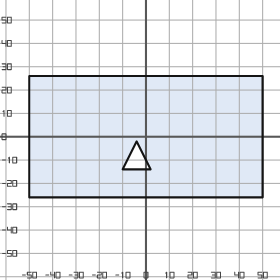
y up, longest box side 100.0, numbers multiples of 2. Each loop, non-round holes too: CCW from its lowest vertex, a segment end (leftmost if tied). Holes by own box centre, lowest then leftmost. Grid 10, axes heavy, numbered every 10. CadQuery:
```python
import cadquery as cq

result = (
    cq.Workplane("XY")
    .moveTo(-50.0, -26.0)
    .lineTo(50.0, -26.0)
    .lineTo(50.0, 26.0)
    .lineTo(-50.0, 26.0)
    .close()
    .moveTo(-10.0, -14.0)
    .lineTo(2.0, -14.0)
    .lineTo(-4.0, -2.0)
    .close()
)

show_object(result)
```